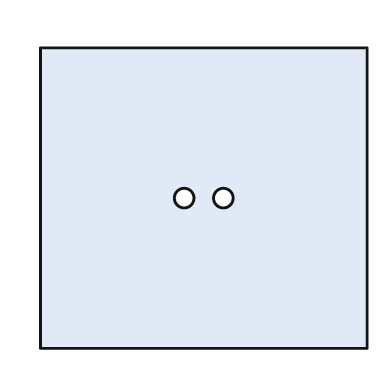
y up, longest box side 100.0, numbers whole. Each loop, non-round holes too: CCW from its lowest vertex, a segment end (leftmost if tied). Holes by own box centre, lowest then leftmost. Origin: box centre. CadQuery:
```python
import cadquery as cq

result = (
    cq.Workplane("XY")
    .moveTo(-50.0, -46.0)
    .lineTo(50.0, -46.0)
    .lineTo(50.0, 46.0)
    .lineTo(-50.0, 46.0)
    .close()
    .moveTo(-6.0, 0.0)
    .circle(3.0)
    .moveTo(6.0, 0.0)
    .circle(3.0)
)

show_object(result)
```